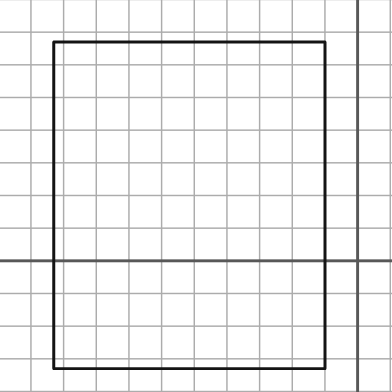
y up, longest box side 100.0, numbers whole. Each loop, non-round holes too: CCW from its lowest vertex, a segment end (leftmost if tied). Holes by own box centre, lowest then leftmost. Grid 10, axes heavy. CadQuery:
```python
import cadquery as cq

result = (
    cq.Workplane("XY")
    .moveTo(-93.0, -33.0)
    .lineTo(-10.0, -33.0)
    .lineTo(-10.0, 67.0)
    .lineTo(-93.0, 67.0)
    .close()
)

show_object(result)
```